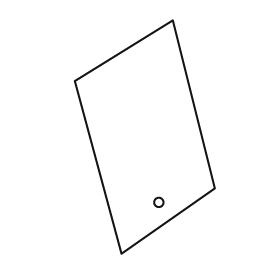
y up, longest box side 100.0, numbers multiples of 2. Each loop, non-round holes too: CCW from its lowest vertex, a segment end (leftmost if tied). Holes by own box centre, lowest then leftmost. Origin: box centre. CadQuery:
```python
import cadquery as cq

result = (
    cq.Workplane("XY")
    .moveTo(-10.0, -50.0)
    .lineTo(30.0, -22.0)
    .lineTo(12.0, 50.0)
    .lineTo(-30.0, 24.0)
    .close()
    .moveTo(6.0, -28.0)
    .circle(2.0)
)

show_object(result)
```